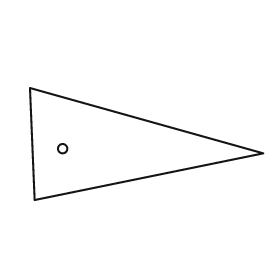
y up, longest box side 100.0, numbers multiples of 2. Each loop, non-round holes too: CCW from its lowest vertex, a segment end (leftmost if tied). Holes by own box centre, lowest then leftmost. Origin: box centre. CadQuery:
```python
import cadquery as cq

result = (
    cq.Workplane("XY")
    .moveTo(-48.0, -24.0)
    .lineTo(50.0, -4.0)
    .lineTo(-50.0, 24.0)
    .close()
    .moveTo(-36.0, -2.0)
    .circle(2.0)
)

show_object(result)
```